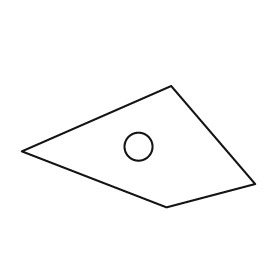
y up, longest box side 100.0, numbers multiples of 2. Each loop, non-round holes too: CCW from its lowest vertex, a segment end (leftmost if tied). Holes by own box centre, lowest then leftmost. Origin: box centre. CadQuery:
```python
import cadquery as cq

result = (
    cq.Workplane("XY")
    .moveTo(12.0, -26.0)
    .lineTo(50.0, -16.0)
    .lineTo(14.0, 26.0)
    .lineTo(-50.0, -2.0)
    .close()
    .moveTo(0.0, 0.0)
    .circle(6.0)
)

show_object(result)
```